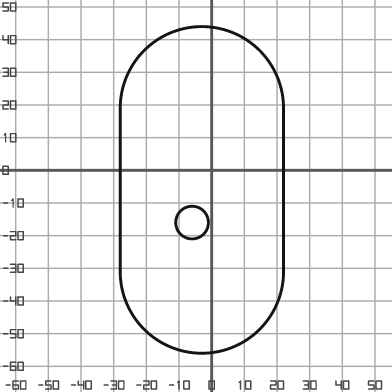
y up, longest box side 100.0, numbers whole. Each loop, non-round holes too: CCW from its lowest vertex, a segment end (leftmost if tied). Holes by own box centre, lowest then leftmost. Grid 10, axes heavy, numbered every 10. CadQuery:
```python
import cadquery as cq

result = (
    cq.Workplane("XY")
    .moveTo(-28.0, -31.0)
    .threePointArc((-3.0, -56.0), (22.0, -31.0))
    .lineTo(22.0, 19.0)
    .threePointArc((-3.0, 44.0), (-28.0, 19.0))
    .close()
    .moveTo(-6.0, -16.0)
    .circle(5.0)
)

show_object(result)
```